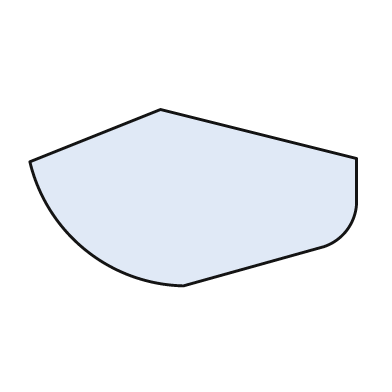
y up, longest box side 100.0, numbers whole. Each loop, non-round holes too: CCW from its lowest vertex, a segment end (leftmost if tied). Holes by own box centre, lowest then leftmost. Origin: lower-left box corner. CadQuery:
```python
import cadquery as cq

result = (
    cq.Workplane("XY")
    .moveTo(47.0, 0.0)
    .lineTo(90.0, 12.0)
    .threePointArc((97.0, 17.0), (100.0, 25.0))
    .lineTo(100.0, 39.0)
    .lineTo(40.0, 54.0)
    .lineTo(0.0, 38.0)
    .threePointArc((17.0, 11.0), (47.0, 0.0))
    .close()
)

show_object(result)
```